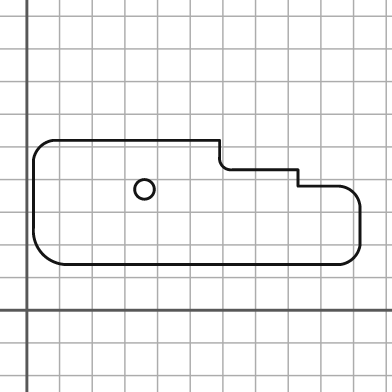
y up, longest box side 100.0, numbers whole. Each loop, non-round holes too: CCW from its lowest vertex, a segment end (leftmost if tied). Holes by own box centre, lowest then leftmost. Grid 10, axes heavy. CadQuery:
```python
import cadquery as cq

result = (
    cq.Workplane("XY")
    .moveTo(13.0, 14.0)
    .lineTo(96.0, 14.0)
    .threePointArc((100.0, 16.0), (102.0, 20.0))
    .lineTo(102.0, 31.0)
    .threePointArc((100.0, 36.0), (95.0, 38.0))
    .lineTo(83.0, 38.0)
    .lineTo(83.0, 43.0)
    .lineTo(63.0, 43.0)
    .threePointArc((60.0, 44.0), (59.0, 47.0))
    .lineTo(59.0, 52.0)
    .lineTo(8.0, 52.0)
    .threePointArc((4.0, 50.0), (2.0, 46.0))
    .lineTo(2.0, 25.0)
    .threePointArc((5.0, 17.0), (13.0, 14.0))
    .close()
    .moveTo(36.0, 37.0)
    .circle(3.0)
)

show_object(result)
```